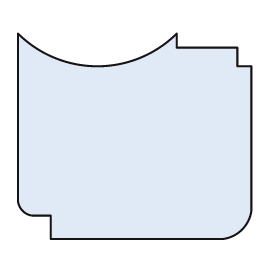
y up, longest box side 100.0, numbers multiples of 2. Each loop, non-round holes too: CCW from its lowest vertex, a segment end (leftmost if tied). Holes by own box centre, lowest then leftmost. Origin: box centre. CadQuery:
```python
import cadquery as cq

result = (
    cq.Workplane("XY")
    .moveTo(-36.0, -44.0)
    .lineTo(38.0, -44.0)
    .threePointArc((46.0, -40.0), (50.0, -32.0))
    .lineTo(50.0, 30.0)
    .lineTo(44.0, 30.0)
    .lineTo(44.0, 38.0)
    .lineTo(18.0, 38.0)
    .lineTo(18.0, 44.0)
    .threePointArc((-16.0, 30.0), (-50.0, 44.0))
    .lineTo(-50.0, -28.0)
    .threePointArc((-48.0, -32.0), (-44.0, -34.0))
    .lineTo(-36.0, -34.0)
    .close()
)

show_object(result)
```